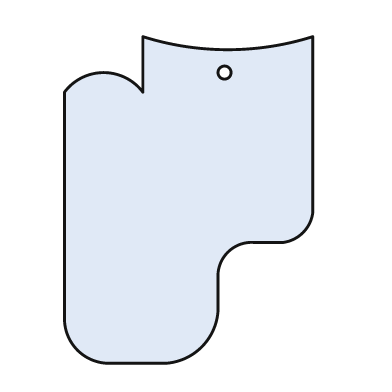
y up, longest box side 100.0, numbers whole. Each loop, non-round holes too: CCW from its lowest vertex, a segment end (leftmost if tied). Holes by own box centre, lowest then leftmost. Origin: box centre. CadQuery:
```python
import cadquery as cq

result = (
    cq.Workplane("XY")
    .moveTo(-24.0, -50.0)
    .lineTo(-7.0, -50.0)
    .threePointArc((4.0, -45.0), (9.0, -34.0))
    .lineTo(9.0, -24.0)
    .threePointArc((12.0, -16.0), (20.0, -13.0))
    .lineTo(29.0, -13.0)
    .threePointArc((35.0, -10.0), (38.0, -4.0))
    .lineTo(38.0, 50.0)
    .threePointArc((12.0, 46.0), (-14.0, 50.0))
    .lineTo(-14.0, 33.0)
    .threePointArc((-26.0, 39.0), (-38.0, 33.0))
    .lineTo(-38.0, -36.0)
    .threePointArc((-34.0, -46.0), (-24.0, -50.0))
    .close()
    .moveTo(11.0, 39.0)
    .circle(2.0)
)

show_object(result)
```